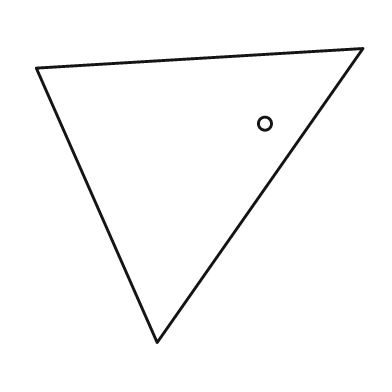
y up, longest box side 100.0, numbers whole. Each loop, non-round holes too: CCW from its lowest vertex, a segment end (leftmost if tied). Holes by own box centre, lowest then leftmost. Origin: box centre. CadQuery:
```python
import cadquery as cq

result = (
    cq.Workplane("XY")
    .moveTo(-13.0, -45.0)
    .lineTo(50.0, 45.0)
    .lineTo(-50.0, 39.0)
    .close()
    .moveTo(20.0, 22.0)
    .circle(2.0)
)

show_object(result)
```